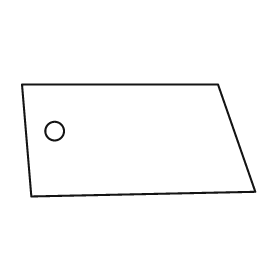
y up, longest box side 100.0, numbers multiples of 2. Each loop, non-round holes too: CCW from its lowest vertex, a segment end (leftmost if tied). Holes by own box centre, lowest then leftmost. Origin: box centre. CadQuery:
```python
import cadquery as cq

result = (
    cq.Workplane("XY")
    .moveTo(-46.0, -24.0)
    .lineTo(50.0, -22.0)
    .lineTo(34.0, 24.0)
    .lineTo(-50.0, 24.0)
    .close()
    .moveTo(-36.0, 4.0)
    .circle(4.0)
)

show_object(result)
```